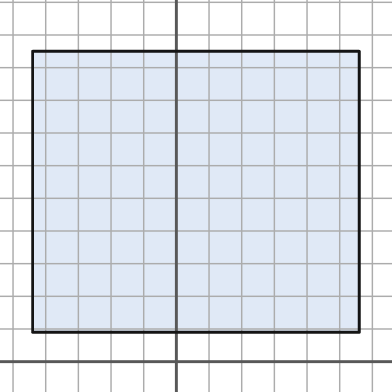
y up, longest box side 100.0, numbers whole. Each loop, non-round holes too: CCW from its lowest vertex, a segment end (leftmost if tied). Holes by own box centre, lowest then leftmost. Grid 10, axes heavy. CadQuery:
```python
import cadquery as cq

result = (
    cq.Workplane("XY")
    .moveTo(-44.0, 9.0)
    .lineTo(56.0, 9.0)
    .lineTo(56.0, 95.0)
    .lineTo(-44.0, 95.0)
    .close()
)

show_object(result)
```